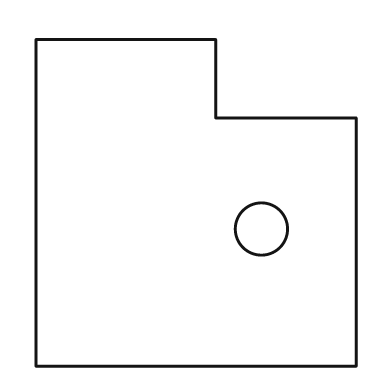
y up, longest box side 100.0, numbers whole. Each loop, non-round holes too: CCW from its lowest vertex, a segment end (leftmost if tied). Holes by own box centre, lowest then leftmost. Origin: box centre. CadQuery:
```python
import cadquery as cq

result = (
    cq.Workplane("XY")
    .moveTo(-49.0, -50.0)
    .lineTo(49.0, -50.0)
    .lineTo(49.0, 26.0)
    .lineTo(6.0, 26.0)
    .lineTo(6.0, 50.0)
    .lineTo(-49.0, 50.0)
    .close()
    .moveTo(20.0, -8.0)
    .circle(8.0)
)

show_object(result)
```